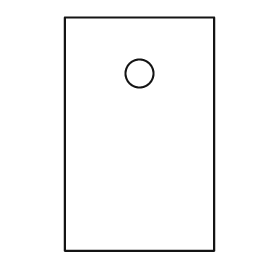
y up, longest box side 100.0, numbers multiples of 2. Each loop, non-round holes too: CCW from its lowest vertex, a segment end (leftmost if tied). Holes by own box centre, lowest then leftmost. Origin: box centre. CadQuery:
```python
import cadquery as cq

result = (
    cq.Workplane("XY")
    .moveTo(-32.0, -50.0)
    .lineTo(32.0, -50.0)
    .lineTo(32.0, 50.0)
    .lineTo(-32.0, 50.0)
    .close()
    .moveTo(0.0, 26.0)
    .circle(6.0)
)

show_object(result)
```